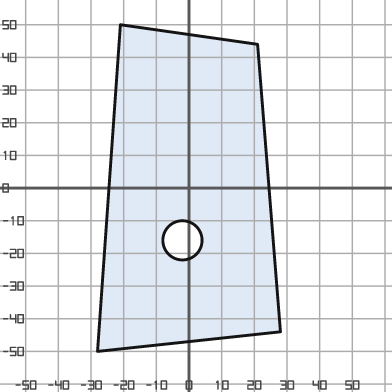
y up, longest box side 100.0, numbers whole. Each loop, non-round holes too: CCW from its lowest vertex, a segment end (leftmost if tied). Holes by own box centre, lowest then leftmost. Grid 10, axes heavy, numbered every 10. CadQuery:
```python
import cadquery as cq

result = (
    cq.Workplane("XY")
    .moveTo(-28.0, -50.0)
    .lineTo(28.0, -44.0)
    .lineTo(21.0, 44.0)
    .lineTo(-21.0, 50.0)
    .close()
    .moveTo(-2.0, -16.0)
    .circle(6.0)
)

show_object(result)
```